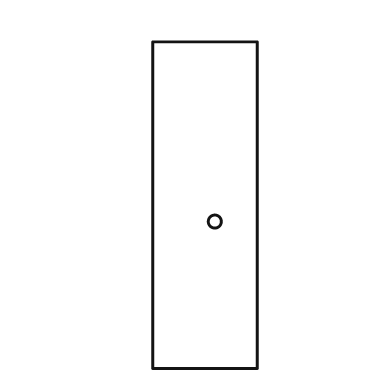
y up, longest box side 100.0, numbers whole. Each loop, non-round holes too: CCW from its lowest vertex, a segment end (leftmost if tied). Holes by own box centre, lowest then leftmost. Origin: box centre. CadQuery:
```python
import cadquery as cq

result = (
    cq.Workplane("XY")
    .moveTo(-16.0, -50.0)
    .lineTo(16.0, -50.0)
    .lineTo(16.0, 50.0)
    .lineTo(-16.0, 50.0)
    .close()
    .moveTo(3.0, -5.0)
    .circle(2.0)
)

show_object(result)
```